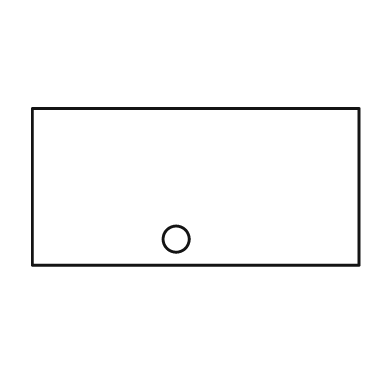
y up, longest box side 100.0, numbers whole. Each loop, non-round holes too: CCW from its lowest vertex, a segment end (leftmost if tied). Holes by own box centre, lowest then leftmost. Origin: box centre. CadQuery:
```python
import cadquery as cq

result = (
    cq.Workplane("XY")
    .moveTo(-50.0, -24.0)
    .lineTo(50.0, -24.0)
    .lineTo(50.0, 24.0)
    .lineTo(-50.0, 24.0)
    .close()
    .moveTo(-6.0, -16.0)
    .circle(4.0)
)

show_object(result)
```